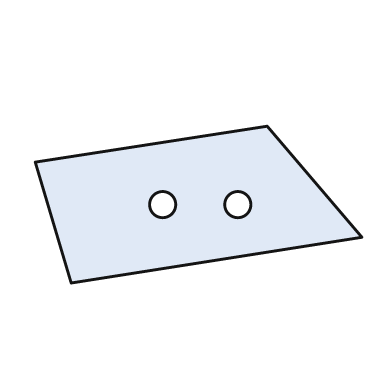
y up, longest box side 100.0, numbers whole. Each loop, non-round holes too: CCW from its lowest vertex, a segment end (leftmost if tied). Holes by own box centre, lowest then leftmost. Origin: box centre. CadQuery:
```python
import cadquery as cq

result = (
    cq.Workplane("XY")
    .moveTo(-39.0, -24.0)
    .lineTo(50.0, -10.0)
    .lineTo(21.0, 24.0)
    .lineTo(-50.0, 13.0)
    .close()
    .moveTo(-11.0, 0.0)
    .circle(4.0)
    .moveTo(12.0, 0.0)
    .circle(4.0)
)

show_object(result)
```